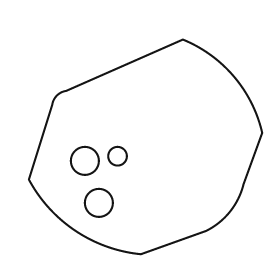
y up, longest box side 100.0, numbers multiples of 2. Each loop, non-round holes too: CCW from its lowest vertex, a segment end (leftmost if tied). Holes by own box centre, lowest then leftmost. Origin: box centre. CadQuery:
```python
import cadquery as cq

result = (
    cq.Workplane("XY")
    .moveTo(-2.0, -46.0)
    .lineTo(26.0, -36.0)
    .threePointArc((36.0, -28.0), (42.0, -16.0))
    .lineTo(50.0, 6.0)
    .threePointArc((38.0, 30.0), (16.0, 46.0))
    .lineTo(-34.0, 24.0)
    .threePointArc((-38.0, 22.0), (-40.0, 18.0))
    .lineTo(-50.0, -14.0)
    .threePointArc((-30.0, -36.0), (-2.0, -46.0))
    .close()
    .moveTo(-20.0, -24.0)
    .circle(6.0)
    .moveTo(-26.0, -6.0)
    .circle(6.0)
    .moveTo(-12.0, -4.0)
    .circle(4.0)
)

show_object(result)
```